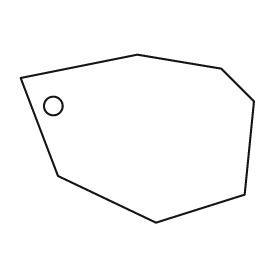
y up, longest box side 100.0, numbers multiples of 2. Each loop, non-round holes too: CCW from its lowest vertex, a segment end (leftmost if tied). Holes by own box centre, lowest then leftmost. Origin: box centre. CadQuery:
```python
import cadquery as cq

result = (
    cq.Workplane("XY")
    .moveTo(8.0, -36.0)
    .lineTo(46.0, -24.0)
    .lineTo(50.0, 16.0)
    .lineTo(36.0, 30.0)
    .lineTo(0.0, 36.0)
    .lineTo(-50.0, 26.0)
    .lineTo(-34.0, -16.0)
    .close()
    .moveTo(-36.0, 14.0)
    .circle(4.0)
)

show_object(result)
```